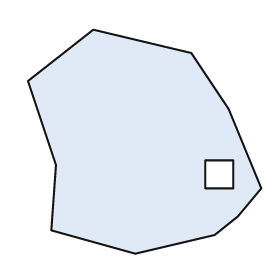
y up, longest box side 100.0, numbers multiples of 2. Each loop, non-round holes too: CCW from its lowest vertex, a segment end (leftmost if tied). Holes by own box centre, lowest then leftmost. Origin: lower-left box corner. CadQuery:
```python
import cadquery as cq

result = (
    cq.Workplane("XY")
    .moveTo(46.0, 0.0)
    .lineTo(80.0, 8.0)
    .lineTo(90.0, 16.0)
    .lineTo(100.0, 28.0)
    .lineTo(86.0, 62.0)
    .lineTo(70.0, 86.0)
    .lineTo(28.0, 96.0)
    .lineTo(0.0, 74.0)
    .lineTo(12.0, 38.0)
    .lineTo(10.0, 10.0)
    .close()
    .moveTo(76.0, 28.0)
    .lineTo(88.0, 28.0)
    .lineTo(88.0, 40.0)
    .lineTo(76.0, 40.0)
    .close()
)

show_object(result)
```